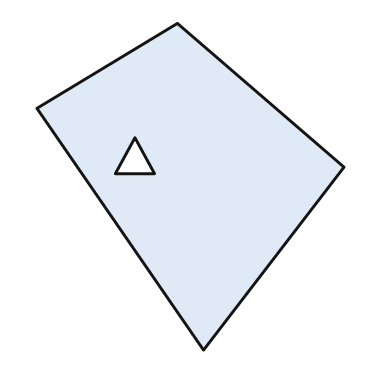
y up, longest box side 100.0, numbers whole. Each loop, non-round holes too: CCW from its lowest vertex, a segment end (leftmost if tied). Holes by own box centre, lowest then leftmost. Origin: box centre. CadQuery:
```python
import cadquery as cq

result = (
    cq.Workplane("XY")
    .moveTo(4.0, -50.0)
    .lineTo(47.0, 6.0)
    .lineTo(-4.0, 50.0)
    .lineTo(-47.0, 24.0)
    .close()
    .moveTo(-23.0, 4.0)
    .lineTo(-11.0, 4.0)
    .lineTo(-17.0, 15.0)
    .close()
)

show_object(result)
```